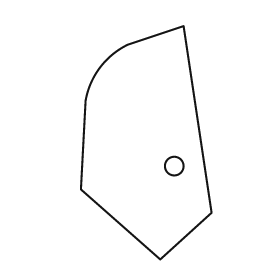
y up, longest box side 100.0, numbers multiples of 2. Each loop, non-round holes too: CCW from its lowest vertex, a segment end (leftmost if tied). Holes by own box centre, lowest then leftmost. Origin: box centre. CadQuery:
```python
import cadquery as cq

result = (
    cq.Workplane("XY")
    .moveTo(6.0, -50.0)
    .lineTo(28.0, -30.0)
    .lineTo(16.0, 50.0)
    .lineTo(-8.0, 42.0)
    .threePointArc((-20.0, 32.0), (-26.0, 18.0))
    .lineTo(-28.0, -20.0)
    .close()
    .moveTo(12.0, -10.0)
    .circle(4.0)
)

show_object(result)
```